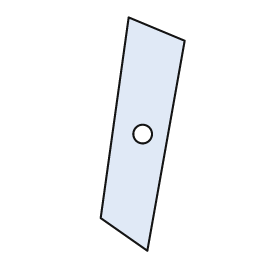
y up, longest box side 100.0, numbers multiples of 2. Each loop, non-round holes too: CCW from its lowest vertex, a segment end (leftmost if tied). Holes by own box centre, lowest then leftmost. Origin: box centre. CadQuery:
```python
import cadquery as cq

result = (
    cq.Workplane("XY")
    .moveTo(2.0, -50.0)
    .lineTo(18.0, 40.0)
    .lineTo(-6.0, 50.0)
    .lineTo(-18.0, -36.0)
    .close()
    .moveTo(0.0, 0.0)
    .circle(4.0)
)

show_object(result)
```